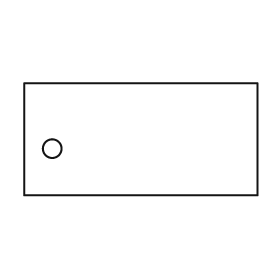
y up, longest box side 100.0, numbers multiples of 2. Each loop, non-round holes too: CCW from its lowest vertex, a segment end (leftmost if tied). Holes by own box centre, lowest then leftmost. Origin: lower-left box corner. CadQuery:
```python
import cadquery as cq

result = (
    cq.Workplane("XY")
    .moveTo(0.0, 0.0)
    .lineTo(100.0, 0.0)
    .lineTo(100.0, 48.0)
    .lineTo(0.0, 48.0)
    .close()
    .moveTo(12.0, 20.0)
    .circle(4.0)
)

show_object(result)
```